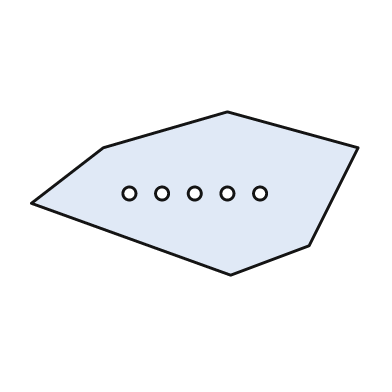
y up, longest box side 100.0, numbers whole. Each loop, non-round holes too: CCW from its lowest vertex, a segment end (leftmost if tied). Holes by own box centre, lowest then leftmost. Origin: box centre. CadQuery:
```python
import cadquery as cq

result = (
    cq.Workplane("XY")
    .moveTo(11.0, -25.0)
    .lineTo(35.0, -16.0)
    .lineTo(50.0, 14.0)
    .lineTo(10.0, 25.0)
    .lineTo(-28.0, 14.0)
    .lineTo(-50.0, -3.0)
    .close()
    .moveTo(-20.0, 0.0)
    .circle(2.0)
    .moveTo(-10.0, 0.0)
    .circle(2.0)
    .moveTo(0.0, 0.0)
    .circle(2.0)
    .moveTo(10.0, 0.0)
    .circle(2.0)
    .moveTo(20.0, 0.0)
    .circle(2.0)
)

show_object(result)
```